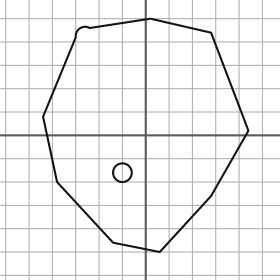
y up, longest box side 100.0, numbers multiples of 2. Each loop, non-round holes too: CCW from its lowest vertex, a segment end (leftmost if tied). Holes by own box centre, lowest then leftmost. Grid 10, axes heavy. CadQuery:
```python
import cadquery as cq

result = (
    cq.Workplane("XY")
    .moveTo(6.0, -50.0)
    .lineTo(28.0, -26.0)
    .lineTo(44.0, 2.0)
    .lineTo(28.0, 44.0)
    .lineTo(2.0, 50.0)
    .lineTo(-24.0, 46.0)
    .threePointArc((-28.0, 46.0), (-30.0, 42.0))
    .lineTo(-44.0, 8.0)
    .lineTo(-38.0, -20.0)
    .lineTo(-14.0, -46.0)
    .close()
    .moveTo(-10.0, -16.0)
    .circle(4.0)
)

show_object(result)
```